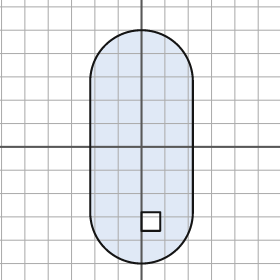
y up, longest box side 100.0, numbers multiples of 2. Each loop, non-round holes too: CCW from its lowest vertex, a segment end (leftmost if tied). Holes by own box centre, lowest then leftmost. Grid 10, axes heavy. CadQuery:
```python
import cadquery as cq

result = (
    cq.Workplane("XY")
    .moveTo(-22.0, -28.0)
    .threePointArc((0.0, -50.0), (22.0, -28.0))
    .lineTo(22.0, 28.0)
    .threePointArc((0.0, 50.0), (-22.0, 28.0))
    .close()
    .moveTo(0.0, -36.0)
    .lineTo(8.0, -36.0)
    .lineTo(8.0, -28.0)
    .lineTo(0.0, -28.0)
    .close()
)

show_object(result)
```